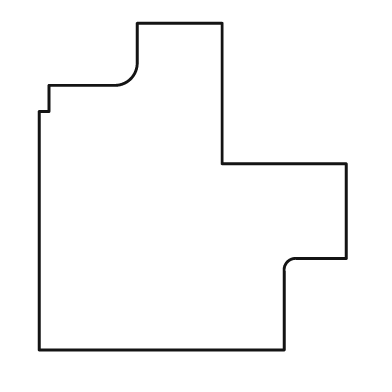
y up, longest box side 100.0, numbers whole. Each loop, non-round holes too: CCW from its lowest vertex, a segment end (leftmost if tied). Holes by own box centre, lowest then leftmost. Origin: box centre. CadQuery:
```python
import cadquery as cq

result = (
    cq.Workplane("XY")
    .moveTo(-47.0, -50.0)
    .lineTo(28.0, -50.0)
    .lineTo(28.0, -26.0)
    .threePointArc((29.0, -23.0), (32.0, -22.0))
    .lineTo(47.0, -22.0)
    .lineTo(47.0, 7.0)
    .lineTo(9.0, 7.0)
    .lineTo(9.0, 50.0)
    .lineTo(-17.0, 50.0)
    .lineTo(-17.0, 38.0)
    .threePointArc((-19.0, 33.0), (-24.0, 31.0))
    .lineTo(-44.0, 31.0)
    .lineTo(-44.0, 23.0)
    .lineTo(-47.0, 23.0)
    .close()
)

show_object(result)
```